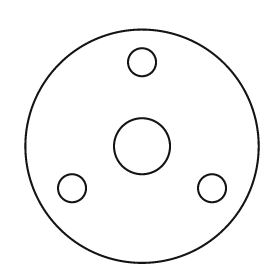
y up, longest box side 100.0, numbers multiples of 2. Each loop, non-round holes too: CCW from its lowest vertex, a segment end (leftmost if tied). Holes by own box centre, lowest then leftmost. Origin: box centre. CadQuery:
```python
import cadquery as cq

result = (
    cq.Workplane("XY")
    .moveTo(0.0, 0.0)
    .circle(50.0)
    .moveTo(-30.0, -18.0)
    .circle(6.0)
    .moveTo(30.0, -18.0)
    .circle(6.0)
    .moveTo(0.0, 0.0)
    .circle(12.0)
    .moveTo(0.0, 36.0)
    .circle(6.0)
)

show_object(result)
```